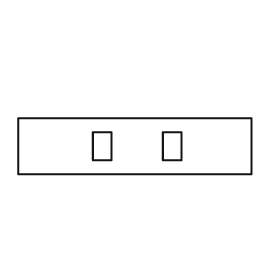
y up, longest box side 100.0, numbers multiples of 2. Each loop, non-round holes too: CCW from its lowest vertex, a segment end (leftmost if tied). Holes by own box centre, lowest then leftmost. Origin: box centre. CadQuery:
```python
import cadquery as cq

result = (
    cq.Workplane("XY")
    .moveTo(-50.0, -12.0)
    .lineTo(50.0, -12.0)
    .lineTo(50.0, 12.0)
    .lineTo(-50.0, 12.0)
    .close()
    .moveTo(-18.0, -6.0)
    .lineTo(-10.0, -6.0)
    .lineTo(-10.0, 6.0)
    .lineTo(-18.0, 6.0)
    .close()
    .moveTo(12.0, -6.0)
    .lineTo(20.0, -6.0)
    .lineTo(20.0, 6.0)
    .lineTo(12.0, 6.0)
    .close()
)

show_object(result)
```